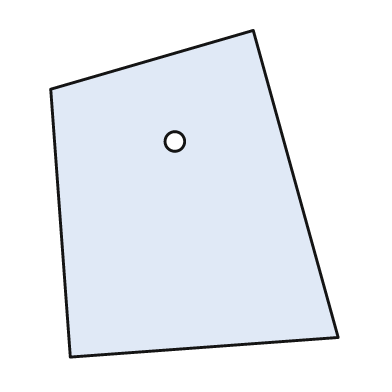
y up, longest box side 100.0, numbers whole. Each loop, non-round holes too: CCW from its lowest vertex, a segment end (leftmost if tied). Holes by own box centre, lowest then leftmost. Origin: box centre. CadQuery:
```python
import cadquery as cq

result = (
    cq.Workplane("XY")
    .moveTo(-38.0, -50.0)
    .lineTo(44.0, -44.0)
    .lineTo(18.0, 50.0)
    .lineTo(-44.0, 32.0)
    .close()
    .moveTo(-6.0, 16.0)
    .circle(3.0)
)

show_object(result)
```